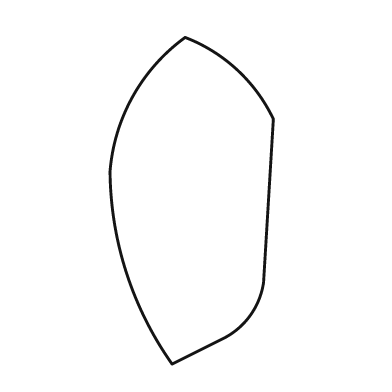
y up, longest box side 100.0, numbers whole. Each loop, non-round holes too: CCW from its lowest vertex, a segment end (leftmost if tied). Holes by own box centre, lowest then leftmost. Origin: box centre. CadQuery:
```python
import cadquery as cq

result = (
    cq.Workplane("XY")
    .moveTo(-6.0, -50.0)
    .lineTo(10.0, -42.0)
    .threePointArc((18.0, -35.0), (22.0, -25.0))
    .lineTo(25.0, 25.0)
    .threePointArc((14.0, 40.0), (-2.0, 50.0))
    .threePointArc((-18.0, 32.0), (-25.0, 9.0))
    .threePointArc((-20.0, -22.0), (-6.0, -50.0))
    .close()
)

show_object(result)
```